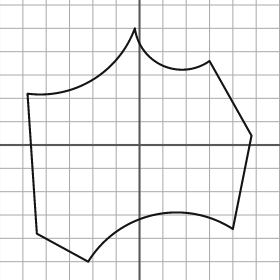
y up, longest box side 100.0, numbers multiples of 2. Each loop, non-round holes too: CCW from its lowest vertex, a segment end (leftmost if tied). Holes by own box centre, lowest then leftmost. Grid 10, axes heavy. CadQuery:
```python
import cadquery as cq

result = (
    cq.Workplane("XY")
    .moveTo(-22.0, -50.0)
    .threePointArc((6.0, -30.0), (40.0, -36.0))
    .lineTo(48.0, 4.0)
    .lineTo(30.0, 36.0)
    .threePointArc((10.0, 34.0), (-2.0, 50.0))
    .threePointArc((-20.0, 28.0), (-48.0, 22.0))
    .lineTo(-44.0, -38.0)
    .close()
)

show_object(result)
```